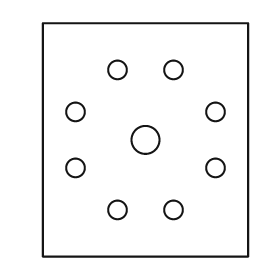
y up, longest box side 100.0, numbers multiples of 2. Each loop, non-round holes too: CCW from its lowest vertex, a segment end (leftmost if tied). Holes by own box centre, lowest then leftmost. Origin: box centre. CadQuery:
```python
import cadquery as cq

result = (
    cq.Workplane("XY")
    .moveTo(-44.0, -50.0)
    .lineTo(44.0, -50.0)
    .lineTo(44.0, 50.0)
    .lineTo(-44.0, 50.0)
    .close()
    .moveTo(-12.0, -30.0)
    .circle(4.0)
    .moveTo(12.0, -30.0)
    .circle(4.0)
    .moveTo(-30.0, -12.0)
    .circle(4.0)
    .moveTo(30.0, -12.0)
    .circle(4.0)
    .moveTo(0.0, 0.0)
    .circle(6.0)
    .moveTo(-30.0, 12.0)
    .circle(4.0)
    .moveTo(30.0, 12.0)
    .circle(4.0)
    .moveTo(-12.0, 30.0)
    .circle(4.0)
    .moveTo(12.0, 30.0)
    .circle(4.0)
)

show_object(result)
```